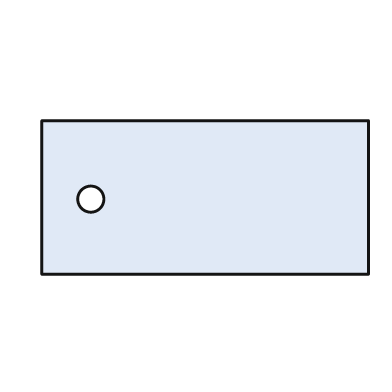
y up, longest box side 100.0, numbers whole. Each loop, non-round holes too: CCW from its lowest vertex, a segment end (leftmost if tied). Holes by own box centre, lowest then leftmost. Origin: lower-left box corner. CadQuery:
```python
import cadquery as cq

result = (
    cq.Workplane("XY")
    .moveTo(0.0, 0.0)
    .lineTo(100.0, 0.0)
    .lineTo(100.0, 47.0)
    .lineTo(0.0, 47.0)
    .close()
    .moveTo(15.0, 23.0)
    .circle(4.0)
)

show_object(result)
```